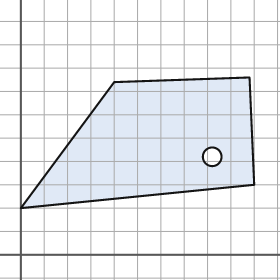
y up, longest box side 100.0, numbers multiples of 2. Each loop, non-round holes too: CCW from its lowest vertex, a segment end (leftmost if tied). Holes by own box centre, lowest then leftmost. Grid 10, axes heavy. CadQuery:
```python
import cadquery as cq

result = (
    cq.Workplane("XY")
    .moveTo(0.0, 20.0)
    .lineTo(100.0, 30.0)
    .lineTo(98.0, 76.0)
    .lineTo(40.0, 74.0)
    .close()
    .moveTo(82.0, 42.0)
    .circle(4.0)
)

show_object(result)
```